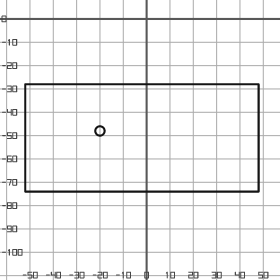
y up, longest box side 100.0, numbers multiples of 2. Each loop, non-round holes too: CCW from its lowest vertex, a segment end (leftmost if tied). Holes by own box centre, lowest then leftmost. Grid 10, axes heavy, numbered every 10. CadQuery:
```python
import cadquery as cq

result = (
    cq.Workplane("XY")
    .moveTo(-52.0, -74.0)
    .lineTo(48.0, -74.0)
    .lineTo(48.0, -28.0)
    .lineTo(-52.0, -28.0)
    .close()
    .moveTo(-20.0, -48.0)
    .circle(2.0)
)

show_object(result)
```